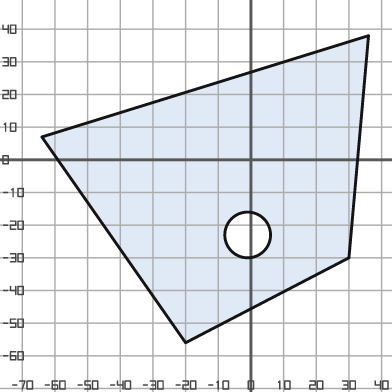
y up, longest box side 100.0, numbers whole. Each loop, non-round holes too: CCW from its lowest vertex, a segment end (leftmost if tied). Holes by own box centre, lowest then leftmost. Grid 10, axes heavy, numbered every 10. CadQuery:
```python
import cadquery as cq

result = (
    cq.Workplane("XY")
    .moveTo(-20.0, -56.0)
    .lineTo(30.0, -30.0)
    .lineTo(36.0, 38.0)
    .lineTo(-64.0, 7.0)
    .close()
    .moveTo(-1.0, -23.0)
    .circle(7.0)
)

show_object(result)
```